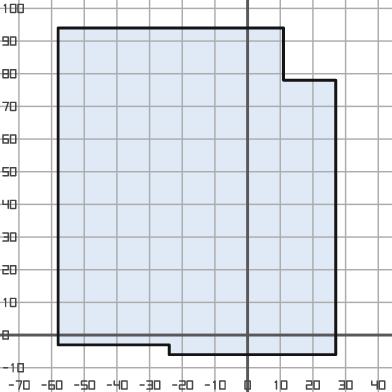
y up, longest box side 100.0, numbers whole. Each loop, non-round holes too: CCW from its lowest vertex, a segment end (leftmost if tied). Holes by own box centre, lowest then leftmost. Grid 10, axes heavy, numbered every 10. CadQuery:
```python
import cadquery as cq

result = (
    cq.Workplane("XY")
    .moveTo(-24.0, -6.0)
    .lineTo(27.0, -6.0)
    .lineTo(27.0, 78.0)
    .lineTo(11.0, 78.0)
    .lineTo(11.0, 94.0)
    .lineTo(-58.0, 94.0)
    .lineTo(-58.0, -3.0)
    .lineTo(-24.0, -3.0)
    .close()
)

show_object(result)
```